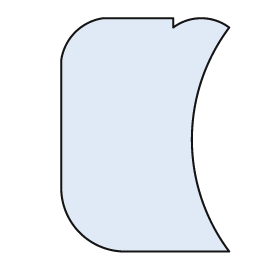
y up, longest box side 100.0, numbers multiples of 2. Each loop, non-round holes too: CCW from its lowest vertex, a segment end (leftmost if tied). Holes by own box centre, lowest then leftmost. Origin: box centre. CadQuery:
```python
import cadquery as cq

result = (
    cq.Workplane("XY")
    .moveTo(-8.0, -50.0)
    .lineTo(36.0, -50.0)
    .threePointArc((20.0, -2.0), (36.0, 46.0))
    .threePointArc((24.0, 50.0), (12.0, 46.0))
    .lineTo(12.0, 50.0)
    .lineTo(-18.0, 50.0)
    .threePointArc((-30.0, 44.0), (-36.0, 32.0))
    .lineTo(-36.0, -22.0)
    .threePointArc((-28.0, -42.0), (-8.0, -50.0))
    .close()
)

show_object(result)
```